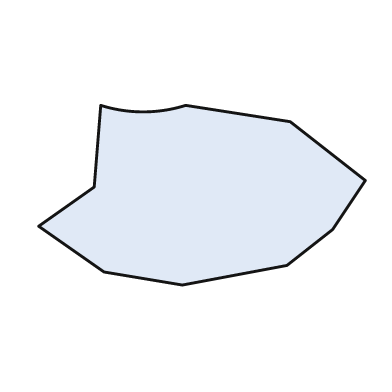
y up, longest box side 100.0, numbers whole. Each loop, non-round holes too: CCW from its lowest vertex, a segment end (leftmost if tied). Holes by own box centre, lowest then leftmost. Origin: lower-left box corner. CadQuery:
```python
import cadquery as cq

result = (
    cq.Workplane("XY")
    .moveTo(44.0, 0.0)
    .lineTo(76.0, 6.0)
    .lineTo(90.0, 17.0)
    .lineTo(100.0, 32.0)
    .lineTo(77.0, 50.0)
    .lineTo(45.0, 55.0)
    .threePointArc((32.0, 53.0), (19.0, 55.0))
    .lineTo(17.0, 30.0)
    .lineTo(0.0, 18.0)
    .lineTo(20.0, 4.0)
    .close()
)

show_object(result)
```